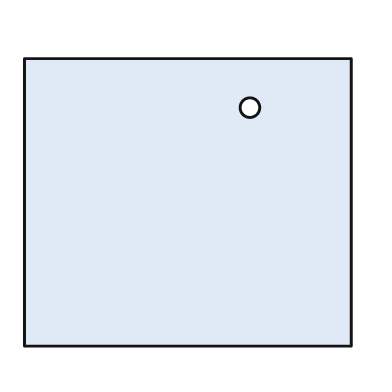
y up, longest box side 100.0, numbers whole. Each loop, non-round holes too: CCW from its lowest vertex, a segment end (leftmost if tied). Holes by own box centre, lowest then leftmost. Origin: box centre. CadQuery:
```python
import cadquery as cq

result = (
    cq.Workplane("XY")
    .moveTo(-50.0, -44.0)
    .lineTo(50.0, -44.0)
    .lineTo(50.0, 44.0)
    .lineTo(-50.0, 44.0)
    .close()
    .moveTo(19.0, 29.0)
    .circle(3.0)
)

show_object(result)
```